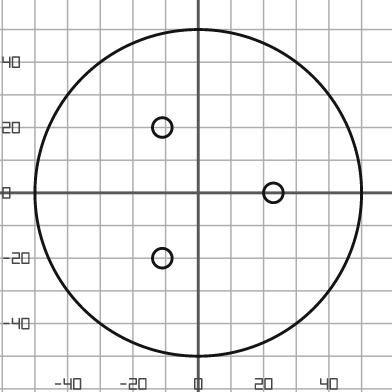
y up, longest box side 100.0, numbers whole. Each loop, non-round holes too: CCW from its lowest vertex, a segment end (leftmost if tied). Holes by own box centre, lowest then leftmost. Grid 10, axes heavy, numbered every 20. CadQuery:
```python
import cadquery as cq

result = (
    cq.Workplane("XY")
    .moveTo(0.0, 0.0)
    .circle(50.0)
    .moveTo(-11.0, -20.0)
    .circle(3.0)
    .moveTo(23.0, 0.0)
    .circle(3.0)
    .moveTo(-11.0, 20.0)
    .circle(3.0)
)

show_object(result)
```